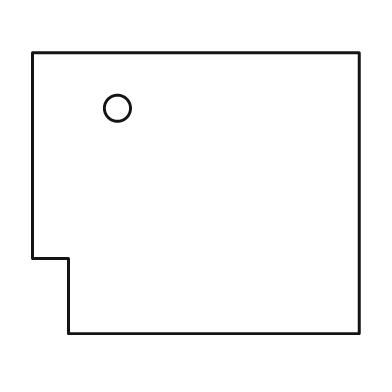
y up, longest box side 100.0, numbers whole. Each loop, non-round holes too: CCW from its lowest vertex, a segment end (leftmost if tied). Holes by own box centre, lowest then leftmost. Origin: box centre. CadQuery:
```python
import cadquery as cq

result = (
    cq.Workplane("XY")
    .moveTo(-39.0, -43.0)
    .lineTo(50.0, -43.0)
    .lineTo(50.0, 43.0)
    .lineTo(-50.0, 43.0)
    .lineTo(-50.0, -20.0)
    .lineTo(-39.0, -20.0)
    .close()
    .moveTo(-24.0, 26.0)
    .circle(4.0)
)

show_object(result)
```